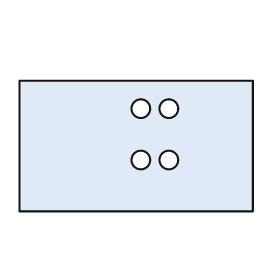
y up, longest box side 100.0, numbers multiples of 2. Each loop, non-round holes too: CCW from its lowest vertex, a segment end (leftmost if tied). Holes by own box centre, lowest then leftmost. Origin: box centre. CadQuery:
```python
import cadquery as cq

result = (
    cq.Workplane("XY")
    .moveTo(-50.0, -28.0)
    .lineTo(50.0, -28.0)
    .lineTo(50.0, 28.0)
    .lineTo(-50.0, 28.0)
    .close()
    .moveTo(2.0, -6.0)
    .circle(4.0)
    .moveTo(14.0, -6.0)
    .circle(4.0)
    .moveTo(2.0, 16.0)
    .circle(4.0)
    .moveTo(14.0, 16.0)
    .circle(4.0)
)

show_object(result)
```